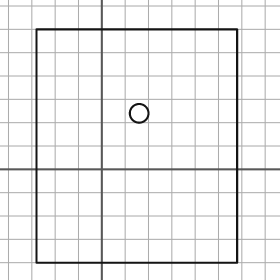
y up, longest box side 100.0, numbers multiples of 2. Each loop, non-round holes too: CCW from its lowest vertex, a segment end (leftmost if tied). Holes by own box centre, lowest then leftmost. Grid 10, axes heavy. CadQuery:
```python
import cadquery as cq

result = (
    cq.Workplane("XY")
    .moveTo(-28.0, -40.0)
    .lineTo(58.0, -40.0)
    .lineTo(58.0, 60.0)
    .lineTo(-28.0, 60.0)
    .close()
    .moveTo(16.0, 24.0)
    .circle(4.0)
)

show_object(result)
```